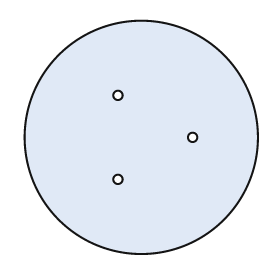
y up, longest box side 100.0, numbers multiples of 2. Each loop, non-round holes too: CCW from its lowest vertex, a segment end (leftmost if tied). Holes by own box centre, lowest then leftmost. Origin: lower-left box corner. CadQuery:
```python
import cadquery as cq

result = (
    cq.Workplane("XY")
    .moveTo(50.0, 50.0)
    .circle(50.0)
    .moveTo(40.0, 32.0)
    .circle(2.0)
    .moveTo(72.0, 50.0)
    .circle(2.0)
    .moveTo(40.0, 68.0)
    .circle(2.0)
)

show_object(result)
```